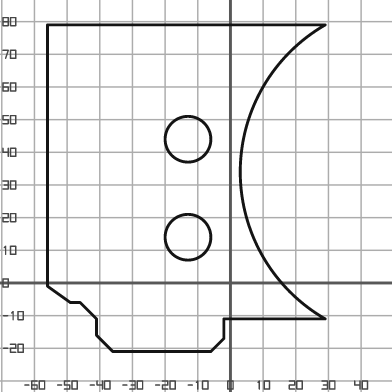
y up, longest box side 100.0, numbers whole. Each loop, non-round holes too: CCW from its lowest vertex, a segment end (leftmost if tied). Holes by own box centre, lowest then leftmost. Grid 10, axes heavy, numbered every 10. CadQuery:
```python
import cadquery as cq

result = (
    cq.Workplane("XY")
    .moveTo(-36.0, -21.0)
    .lineTo(-6.0, -21.0)
    .lineTo(-2.0, -17.0)
    .lineTo(-2.0, -11.0)
    .lineTo(29.0, -11.0)
    .threePointArc((3.0, 34.0), (29.0, 79.0))
    .lineTo(-56.0, 79.0)
    .lineTo(-56.0, -1.0)
    .lineTo(-49.0, -6.0)
    .lineTo(-46.0, -6.0)
    .lineTo(-41.0, -11.0)
    .lineTo(-41.0, -16.0)
    .close()
    .moveTo(-13.0, 14.0)
    .circle(7.0)
    .moveTo(-13.0, 44.0)
    .circle(7.0)
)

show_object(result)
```